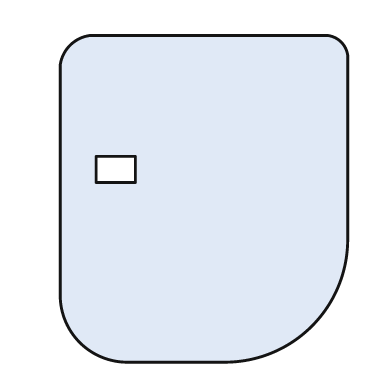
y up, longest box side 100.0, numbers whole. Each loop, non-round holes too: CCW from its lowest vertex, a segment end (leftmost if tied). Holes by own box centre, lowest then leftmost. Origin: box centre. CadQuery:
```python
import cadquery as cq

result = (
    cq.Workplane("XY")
    .moveTo(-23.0, -50.0)
    .lineTo(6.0, -50.0)
    .threePointArc((33.0, -39.0), (44.0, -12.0))
    .lineTo(44.0, 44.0)
    .threePointArc((42.0, 48.0), (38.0, 50.0))
    .lineTo(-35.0, 50.0)
    .threePointArc((-41.0, 47.0), (-44.0, 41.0))
    .lineTo(-44.0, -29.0)
    .threePointArc((-38.0, -44.0), (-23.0, -50.0))
    .close()
    .moveTo(-33.0, 5.0)
    .lineTo(-21.0, 5.0)
    .lineTo(-21.0, 13.0)
    .lineTo(-33.0, 13.0)
    .close()
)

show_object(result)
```